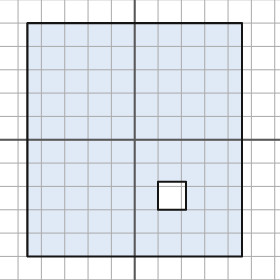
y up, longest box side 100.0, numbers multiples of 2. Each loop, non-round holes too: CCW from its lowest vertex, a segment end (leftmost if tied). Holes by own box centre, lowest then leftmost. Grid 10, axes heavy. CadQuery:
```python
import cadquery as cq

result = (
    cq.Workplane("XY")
    .moveTo(-46.0, -50.0)
    .lineTo(46.0, -50.0)
    .lineTo(46.0, 50.0)
    .lineTo(-46.0, 50.0)
    .close()
    .moveTo(10.0, -30.0)
    .lineTo(22.0, -30.0)
    .lineTo(22.0, -18.0)
    .lineTo(10.0, -18.0)
    .close()
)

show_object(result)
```